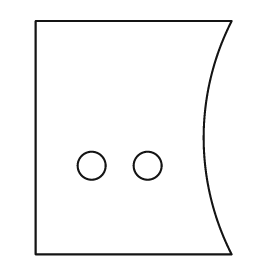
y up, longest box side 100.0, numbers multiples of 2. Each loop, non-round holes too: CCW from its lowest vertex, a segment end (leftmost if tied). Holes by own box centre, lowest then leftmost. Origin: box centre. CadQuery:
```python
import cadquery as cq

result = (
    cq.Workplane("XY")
    .moveTo(-42.0, -50.0)
    .lineTo(42.0, -50.0)
    .threePointArc((30.0, 0.0), (42.0, 50.0))
    .lineTo(-42.0, 50.0)
    .close()
    .moveTo(-18.0, -12.0)
    .circle(6.0)
    .moveTo(6.0, -12.0)
    .circle(6.0)
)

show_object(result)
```